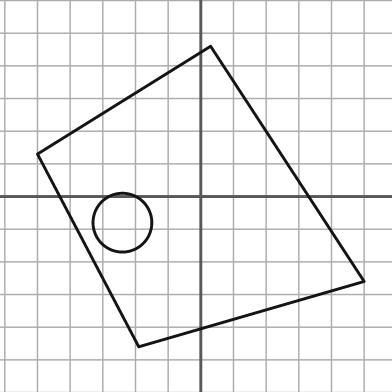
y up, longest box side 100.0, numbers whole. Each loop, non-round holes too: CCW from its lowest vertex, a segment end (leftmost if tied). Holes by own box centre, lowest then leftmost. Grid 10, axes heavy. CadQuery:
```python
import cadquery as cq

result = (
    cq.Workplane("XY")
    .moveTo(-19.0, -46.0)
    .lineTo(50.0, -26.0)
    .lineTo(3.0, 46.0)
    .lineTo(-50.0, 13.0)
    .close()
    .moveTo(-24.0, -8.0)
    .circle(9.0)
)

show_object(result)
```